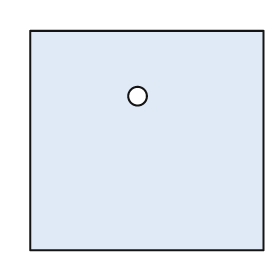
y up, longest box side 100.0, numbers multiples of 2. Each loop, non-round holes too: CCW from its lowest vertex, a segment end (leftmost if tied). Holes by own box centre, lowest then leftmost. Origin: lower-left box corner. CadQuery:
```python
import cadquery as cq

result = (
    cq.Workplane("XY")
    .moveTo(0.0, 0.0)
    .lineTo(100.0, 0.0)
    .lineTo(100.0, 94.0)
    .lineTo(0.0, 94.0)
    .close()
    .moveTo(46.0, 66.0)
    .circle(4.0)
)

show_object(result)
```